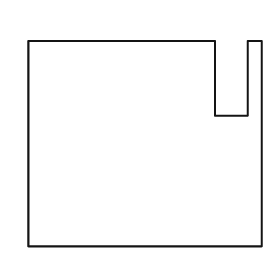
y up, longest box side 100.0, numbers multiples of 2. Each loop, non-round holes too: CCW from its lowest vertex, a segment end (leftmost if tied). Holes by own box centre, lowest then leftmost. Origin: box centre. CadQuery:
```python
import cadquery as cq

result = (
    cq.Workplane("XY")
    .moveTo(-50.0, -44.0)
    .lineTo(50.0, -44.0)
    .lineTo(50.0, 44.0)
    .lineTo(44.0, 44.0)
    .lineTo(44.0, 12.0)
    .lineTo(30.0, 12.0)
    .lineTo(30.0, 44.0)
    .lineTo(-50.0, 44.0)
    .close()
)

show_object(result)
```